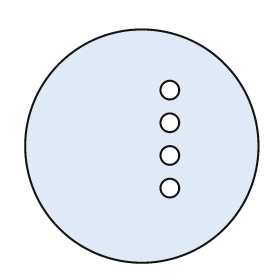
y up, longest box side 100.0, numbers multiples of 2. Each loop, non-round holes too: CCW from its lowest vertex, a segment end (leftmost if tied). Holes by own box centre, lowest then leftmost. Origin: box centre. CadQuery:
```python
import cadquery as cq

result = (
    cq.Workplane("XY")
    .moveTo(0.0, 0.0)
    .circle(50.0)
    .moveTo(12.0, -18.0)
    .circle(4.0)
    .moveTo(12.0, -4.0)
    .circle(4.0)
    .moveTo(12.0, 10.0)
    .circle(4.0)
    .moveTo(12.0, 24.0)
    .circle(4.0)
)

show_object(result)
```